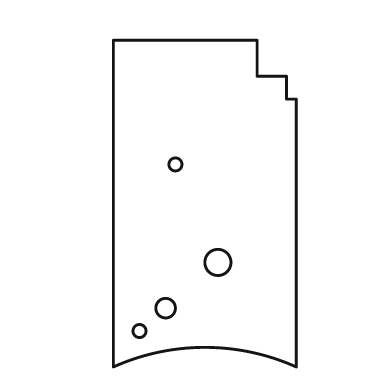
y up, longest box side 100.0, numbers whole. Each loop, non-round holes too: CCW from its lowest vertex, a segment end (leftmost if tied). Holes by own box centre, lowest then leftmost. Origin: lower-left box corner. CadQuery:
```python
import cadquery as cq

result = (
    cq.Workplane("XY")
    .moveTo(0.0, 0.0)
    .threePointArc((28.0, 6.0), (56.0, 0.0))
    .lineTo(56.0, 82.0)
    .lineTo(53.0, 82.0)
    .lineTo(53.0, 89.0)
    .lineTo(44.0, 89.0)
    .lineTo(44.0, 100.0)
    .lineTo(0.0, 100.0)
    .close()
    .moveTo(8.0, 11.0)
    .circle(2.0)
    .moveTo(16.0, 18.0)
    .circle(3.0)
    .moveTo(32.0, 32.0)
    .circle(4.0)
    .moveTo(19.0, 62.0)
    .circle(2.0)
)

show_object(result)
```